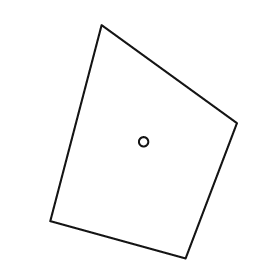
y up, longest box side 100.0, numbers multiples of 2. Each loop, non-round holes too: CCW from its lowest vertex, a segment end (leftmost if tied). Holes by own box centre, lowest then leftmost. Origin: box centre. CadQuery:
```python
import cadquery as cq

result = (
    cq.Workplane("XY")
    .moveTo(18.0, -50.0)
    .lineTo(40.0, 8.0)
    .lineTo(-18.0, 50.0)
    .lineTo(-40.0, -34.0)
    .close()
    .moveTo(0.0, 0.0)
    .circle(2.0)
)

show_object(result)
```